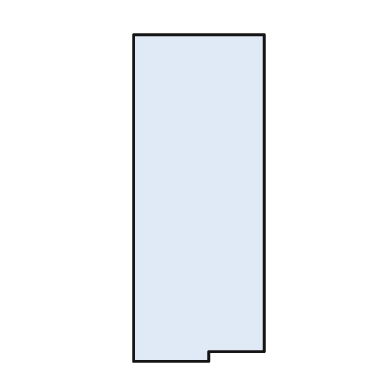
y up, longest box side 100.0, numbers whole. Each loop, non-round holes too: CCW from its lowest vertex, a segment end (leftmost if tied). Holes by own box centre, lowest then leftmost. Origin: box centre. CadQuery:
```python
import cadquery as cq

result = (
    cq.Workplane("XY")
    .moveTo(-20.0, -50.0)
    .lineTo(3.0, -50.0)
    .lineTo(3.0, -47.0)
    .lineTo(20.0, -47.0)
    .lineTo(20.0, 50.0)
    .lineTo(-20.0, 50.0)
    .close()
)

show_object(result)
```